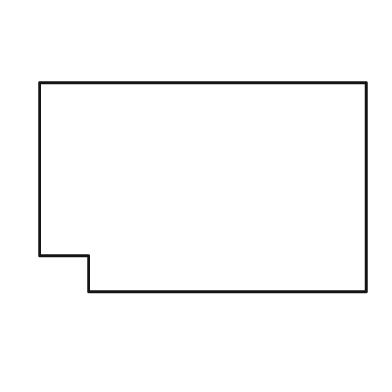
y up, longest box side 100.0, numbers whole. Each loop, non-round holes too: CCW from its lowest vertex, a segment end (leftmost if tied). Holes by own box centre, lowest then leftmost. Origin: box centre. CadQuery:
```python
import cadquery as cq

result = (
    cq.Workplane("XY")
    .moveTo(-35.0, -32.0)
    .lineTo(50.0, -32.0)
    .lineTo(50.0, 32.0)
    .lineTo(-50.0, 32.0)
    .lineTo(-50.0, -21.0)
    .lineTo(-35.0, -21.0)
    .close()
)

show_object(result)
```